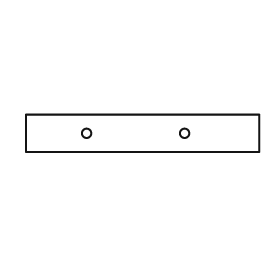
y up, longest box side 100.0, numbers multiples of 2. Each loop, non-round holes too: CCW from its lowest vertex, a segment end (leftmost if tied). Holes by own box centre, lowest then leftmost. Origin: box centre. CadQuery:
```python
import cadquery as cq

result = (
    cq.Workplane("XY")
    .moveTo(-50.0, -8.0)
    .lineTo(50.0, -8.0)
    .lineTo(50.0, 8.0)
    .lineTo(-50.0, 8.0)
    .close()
    .moveTo(-24.0, 0.0)
    .circle(2.0)
    .moveTo(18.0, 0.0)
    .circle(2.0)
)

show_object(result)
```